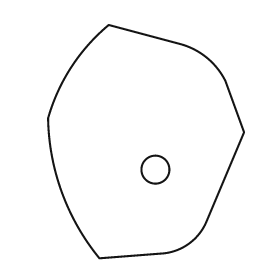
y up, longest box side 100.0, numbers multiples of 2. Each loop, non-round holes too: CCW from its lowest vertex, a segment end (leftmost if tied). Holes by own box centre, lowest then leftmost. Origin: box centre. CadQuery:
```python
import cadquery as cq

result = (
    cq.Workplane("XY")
    .moveTo(-20.0, -50.0)
    .lineTo(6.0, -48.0)
    .threePointArc((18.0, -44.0), (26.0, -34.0))
    .lineTo(42.0, 4.0)
    .lineTo(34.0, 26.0)
    .threePointArc((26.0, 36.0), (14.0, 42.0))
    .lineTo(-16.0, 50.0)
    .threePointArc((-32.0, 32.0), (-42.0, 10.0))
    .threePointArc((-36.0, -22.0), (-20.0, -50.0))
    .close()
    .moveTo(4.0, -12.0)
    .circle(6.0)
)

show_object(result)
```